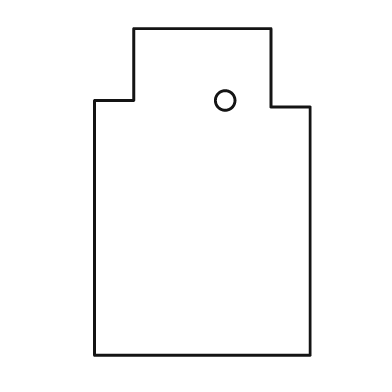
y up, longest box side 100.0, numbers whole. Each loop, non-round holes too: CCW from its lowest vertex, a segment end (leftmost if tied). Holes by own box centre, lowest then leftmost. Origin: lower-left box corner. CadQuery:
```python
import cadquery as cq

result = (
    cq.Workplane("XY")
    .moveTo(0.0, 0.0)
    .lineTo(66.0, 0.0)
    .lineTo(66.0, 76.0)
    .lineTo(54.0, 76.0)
    .lineTo(54.0, 100.0)
    .lineTo(12.0, 100.0)
    .lineTo(12.0, 78.0)
    .lineTo(0.0, 78.0)
    .close()
    .moveTo(40.0, 78.0)
    .circle(3.0)
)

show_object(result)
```